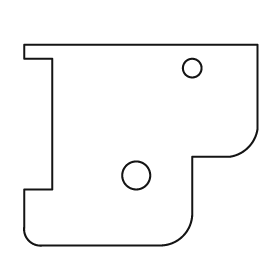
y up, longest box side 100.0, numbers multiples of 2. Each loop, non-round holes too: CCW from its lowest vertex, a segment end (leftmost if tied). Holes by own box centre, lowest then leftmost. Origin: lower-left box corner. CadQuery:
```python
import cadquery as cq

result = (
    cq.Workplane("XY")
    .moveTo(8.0, 0.0)
    .lineTo(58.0, 0.0)
    .threePointArc((68.0, 4.0), (72.0, 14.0))
    .lineTo(72.0, 38.0)
    .lineTo(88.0, 38.0)
    .threePointArc((96.0, 42.0), (100.0, 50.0))
    .lineTo(100.0, 86.0)
    .lineTo(0.0, 86.0)
    .lineTo(0.0, 80.0)
    .lineTo(12.0, 80.0)
    .lineTo(12.0, 24.0)
    .lineTo(0.0, 24.0)
    .lineTo(0.0, 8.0)
    .threePointArc((2.0, 2.0), (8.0, 0.0))
    .close()
    .moveTo(48.0, 30.0)
    .circle(6.0)
    .moveTo(72.0, 76.0)
    .circle(4.0)
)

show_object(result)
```